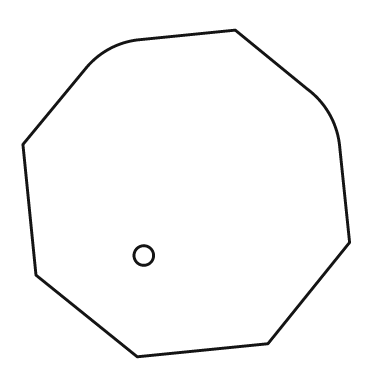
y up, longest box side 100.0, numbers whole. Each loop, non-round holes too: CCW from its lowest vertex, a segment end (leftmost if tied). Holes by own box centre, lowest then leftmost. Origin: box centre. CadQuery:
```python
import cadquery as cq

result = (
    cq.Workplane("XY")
    .moveTo(-15.0, -50.0)
    .lineTo(25.0, -46.0)
    .lineTo(50.0, -15.0)
    .lineTo(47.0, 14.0)
    .threePointArc((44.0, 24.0), (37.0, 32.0))
    .lineTo(15.0, 50.0)
    .lineTo(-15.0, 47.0)
    .threePointArc((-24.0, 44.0), (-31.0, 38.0))
    .lineTo(-50.0, 15.0)
    .lineTo(-46.0, -25.0)
    .close()
    .moveTo(-13.0, -19.0)
    .circle(3.0)
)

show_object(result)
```